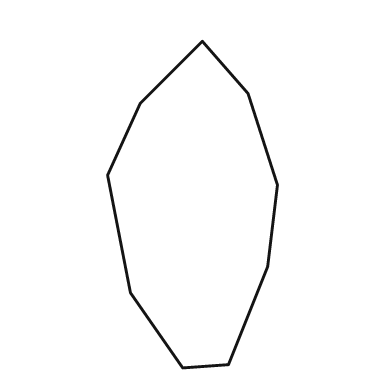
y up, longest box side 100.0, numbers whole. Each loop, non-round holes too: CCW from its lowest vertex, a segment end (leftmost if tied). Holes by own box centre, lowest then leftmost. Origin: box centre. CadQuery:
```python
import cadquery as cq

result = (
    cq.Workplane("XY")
    .moveTo(-3.0, -50.0)
    .lineTo(11.0, -49.0)
    .lineTo(23.0, -19.0)
    .lineTo(26.0, 6.0)
    .lineTo(17.0, 34.0)
    .lineTo(3.0, 50.0)
    .lineTo(-16.0, 31.0)
    .lineTo(-26.0, 9.0)
    .lineTo(-19.0, -27.0)
    .close()
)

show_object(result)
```